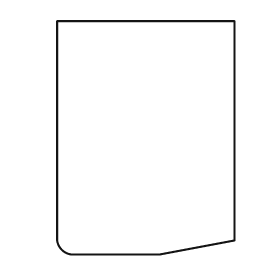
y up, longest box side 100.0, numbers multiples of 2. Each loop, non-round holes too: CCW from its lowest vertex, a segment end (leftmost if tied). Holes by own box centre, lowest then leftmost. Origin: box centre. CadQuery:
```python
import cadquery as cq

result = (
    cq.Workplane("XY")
    .moveTo(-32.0, -50.0)
    .lineTo(6.0, -50.0)
    .lineTo(38.0, -44.0)
    .lineTo(38.0, 50.0)
    .lineTo(-38.0, 50.0)
    .lineTo(-38.0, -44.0)
    .threePointArc((-36.0, -48.0), (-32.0, -50.0))
    .close()
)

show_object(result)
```